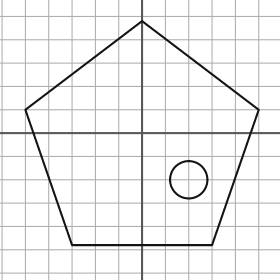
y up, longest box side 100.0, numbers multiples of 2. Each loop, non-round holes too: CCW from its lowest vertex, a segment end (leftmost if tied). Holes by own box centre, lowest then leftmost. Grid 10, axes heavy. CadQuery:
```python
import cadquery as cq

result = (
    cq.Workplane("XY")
    .moveTo(-30.0, -48.0)
    .lineTo(30.0, -48.0)
    .lineTo(50.0, 10.0)
    .lineTo(0.0, 48.0)
    .lineTo(-50.0, 10.0)
    .close()
    .moveTo(20.0, -20.0)
    .circle(8.0)
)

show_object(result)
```